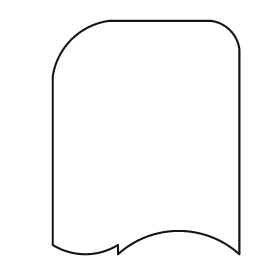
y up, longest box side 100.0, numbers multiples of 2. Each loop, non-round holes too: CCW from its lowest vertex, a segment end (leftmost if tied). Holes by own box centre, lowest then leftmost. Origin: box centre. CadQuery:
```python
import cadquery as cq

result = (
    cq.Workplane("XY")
    .moveTo(-12.0, -50.0)
    .threePointArc((14.0, -40.0), (40.0, -50.0))
    .lineTo(40.0, 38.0)
    .threePointArc((36.0, 46.0), (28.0, 50.0))
    .lineTo(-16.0, 50.0)
    .threePointArc((-32.0, 42.0), (-40.0, 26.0))
    .lineTo(-40.0, -46.0)
    .threePointArc((-26.0, -50.0), (-12.0, -46.0))
    .close()
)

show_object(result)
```